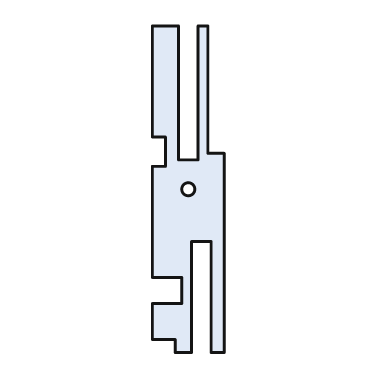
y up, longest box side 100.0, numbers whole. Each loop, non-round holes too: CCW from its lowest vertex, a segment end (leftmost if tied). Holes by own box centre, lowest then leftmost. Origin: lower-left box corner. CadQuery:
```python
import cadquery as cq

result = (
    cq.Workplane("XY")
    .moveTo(7.0, 0.0)
    .lineTo(12.0, 0.0)
    .lineTo(12.0, 34.0)
    .lineTo(18.0, 34.0)
    .lineTo(18.0, 0.0)
    .lineTo(22.0, 0.0)
    .lineTo(22.0, 61.0)
    .lineTo(17.0, 61.0)
    .lineTo(17.0, 100.0)
    .lineTo(14.0, 100.0)
    .lineTo(14.0, 59.0)
    .lineTo(8.0, 59.0)
    .lineTo(8.0, 100.0)
    .lineTo(0.0, 100.0)
    .lineTo(0.0, 66.0)
    .lineTo(4.0, 66.0)
    .lineTo(4.0, 57.0)
    .lineTo(0.0, 57.0)
    .lineTo(0.0, 23.0)
    .lineTo(9.0, 23.0)
    .lineTo(9.0, 15.0)
    .lineTo(0.0, 15.0)
    .lineTo(0.0, 4.0)
    .lineTo(7.0, 4.0)
    .close()
    .moveTo(11.0, 50.0)
    .circle(2.0)
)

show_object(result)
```